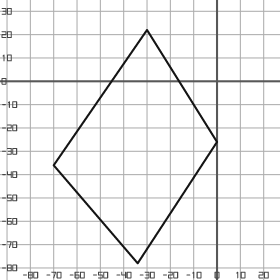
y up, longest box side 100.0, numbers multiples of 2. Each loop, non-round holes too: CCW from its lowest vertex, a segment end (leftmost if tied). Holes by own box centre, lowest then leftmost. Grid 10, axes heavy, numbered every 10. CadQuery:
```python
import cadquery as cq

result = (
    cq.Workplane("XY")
    .moveTo(-34.0, -78.0)
    .lineTo(0.0, -26.0)
    .lineTo(-30.0, 22.0)
    .lineTo(-70.0, -36.0)
    .close()
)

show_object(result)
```